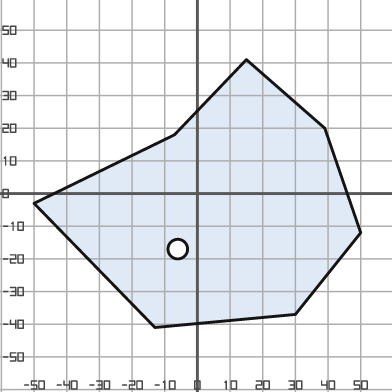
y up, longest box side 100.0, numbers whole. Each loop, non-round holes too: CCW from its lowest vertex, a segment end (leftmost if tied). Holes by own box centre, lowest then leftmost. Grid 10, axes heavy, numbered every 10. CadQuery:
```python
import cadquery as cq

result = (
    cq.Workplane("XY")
    .moveTo(-13.0, -41.0)
    .lineTo(30.0, -37.0)
    .lineTo(50.0, -12.0)
    .lineTo(39.0, 20.0)
    .lineTo(15.0, 41.0)
    .lineTo(-7.0, 18.0)
    .lineTo(-50.0, -3.0)
    .close()
    .moveTo(-6.0, -17.0)
    .circle(3.0)
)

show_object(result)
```